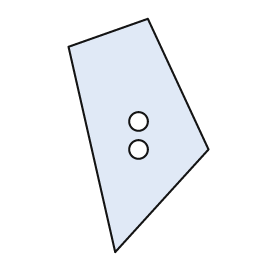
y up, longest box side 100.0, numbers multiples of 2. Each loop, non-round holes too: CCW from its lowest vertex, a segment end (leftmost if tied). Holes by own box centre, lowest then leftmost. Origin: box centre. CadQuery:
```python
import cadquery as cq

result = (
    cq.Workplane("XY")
    .moveTo(-10.0, -50.0)
    .lineTo(30.0, -6.0)
    .lineTo(4.0, 50.0)
    .lineTo(-30.0, 38.0)
    .close()
    .moveTo(0.0, -6.0)
    .circle(4.0)
    .moveTo(0.0, 6.0)
    .circle(4.0)
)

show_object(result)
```